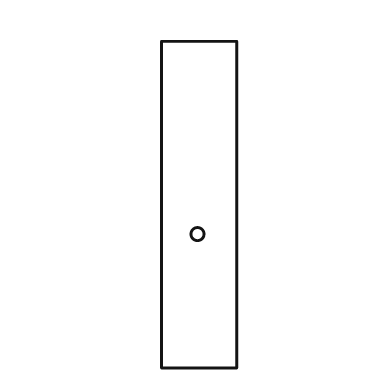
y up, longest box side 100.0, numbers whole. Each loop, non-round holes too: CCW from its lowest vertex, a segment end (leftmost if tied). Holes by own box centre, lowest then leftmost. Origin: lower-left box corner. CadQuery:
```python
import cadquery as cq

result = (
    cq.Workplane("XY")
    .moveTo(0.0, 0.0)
    .lineTo(23.0, 0.0)
    .lineTo(23.0, 100.0)
    .lineTo(0.0, 100.0)
    .close()
    .moveTo(11.0, 41.0)
    .circle(2.0)
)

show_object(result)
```